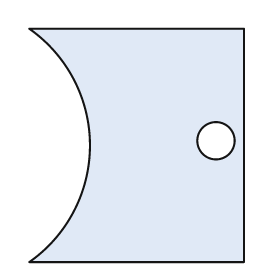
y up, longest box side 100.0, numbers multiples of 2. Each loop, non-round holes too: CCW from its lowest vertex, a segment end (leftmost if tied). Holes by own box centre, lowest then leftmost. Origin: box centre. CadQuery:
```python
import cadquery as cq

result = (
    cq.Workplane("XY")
    .moveTo(-46.0, -50.0)
    .lineTo(46.0, -50.0)
    .lineTo(46.0, 50.0)
    .lineTo(-46.0, 50.0)
    .threePointArc((-20.0, 0.0), (-46.0, -50.0))
    .close()
    .moveTo(34.0, 2.0)
    .circle(8.0)
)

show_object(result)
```